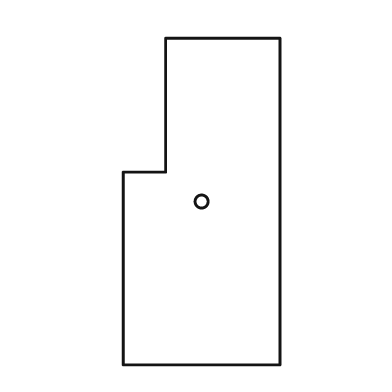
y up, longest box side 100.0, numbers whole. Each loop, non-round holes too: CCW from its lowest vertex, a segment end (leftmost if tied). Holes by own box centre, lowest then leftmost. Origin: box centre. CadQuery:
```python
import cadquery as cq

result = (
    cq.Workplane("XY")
    .moveTo(-24.0, -50.0)
    .lineTo(24.0, -50.0)
    .lineTo(24.0, 50.0)
    .lineTo(-11.0, 50.0)
    .lineTo(-11.0, 9.0)
    .lineTo(-24.0, 9.0)
    .close()
    .moveTo(0.0, 0.0)
    .circle(2.0)
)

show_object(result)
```